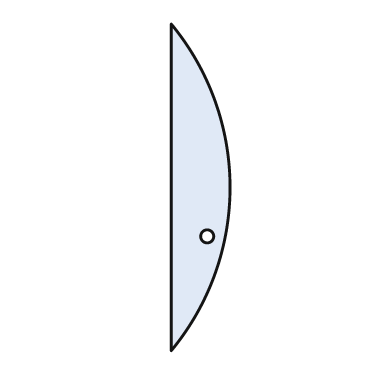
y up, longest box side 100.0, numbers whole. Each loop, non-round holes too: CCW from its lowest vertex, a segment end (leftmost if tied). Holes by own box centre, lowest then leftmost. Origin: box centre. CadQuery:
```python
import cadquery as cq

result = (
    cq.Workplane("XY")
    .moveTo(-9.0, -50.0)
    .threePointArc((9.0, 0.0), (-9.0, 50.0))
    .close()
    .moveTo(2.0, -15.0)
    .circle(2.0)
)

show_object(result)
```